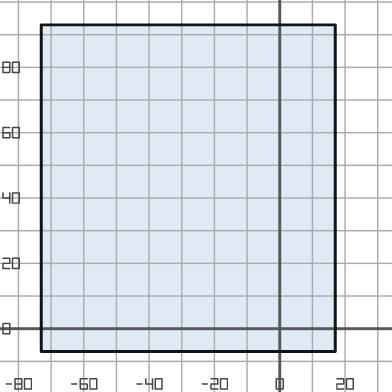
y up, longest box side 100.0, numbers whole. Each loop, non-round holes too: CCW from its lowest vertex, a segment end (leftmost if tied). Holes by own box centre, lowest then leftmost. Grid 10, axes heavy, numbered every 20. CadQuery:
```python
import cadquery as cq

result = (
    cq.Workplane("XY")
    .moveTo(-73.0, -7.0)
    .lineTo(17.0, -7.0)
    .lineTo(17.0, 93.0)
    .lineTo(-73.0, 93.0)
    .close()
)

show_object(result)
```